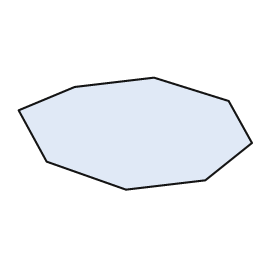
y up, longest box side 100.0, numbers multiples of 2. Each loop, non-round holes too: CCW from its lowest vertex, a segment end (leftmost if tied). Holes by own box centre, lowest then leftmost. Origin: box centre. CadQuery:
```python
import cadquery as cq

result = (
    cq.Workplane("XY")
    .moveTo(-4.0, -24.0)
    .lineTo(30.0, -20.0)
    .lineTo(50.0, -4.0)
    .lineTo(40.0, 14.0)
    .lineTo(8.0, 24.0)
    .lineTo(-26.0, 20.0)
    .lineTo(-50.0, 10.0)
    .lineTo(-38.0, -12.0)
    .close()
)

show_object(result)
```